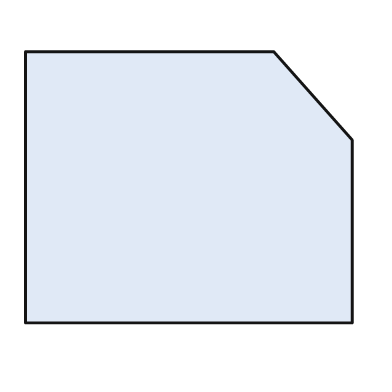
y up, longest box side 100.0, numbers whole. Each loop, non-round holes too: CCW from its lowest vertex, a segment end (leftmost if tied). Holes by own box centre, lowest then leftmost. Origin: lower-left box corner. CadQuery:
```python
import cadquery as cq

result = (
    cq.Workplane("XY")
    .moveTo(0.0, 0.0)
    .lineTo(100.0, 0.0)
    .lineTo(100.0, 56.0)
    .lineTo(76.0, 83.0)
    .lineTo(0.0, 83.0)
    .close()
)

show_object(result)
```